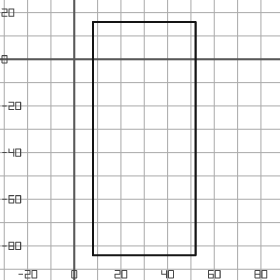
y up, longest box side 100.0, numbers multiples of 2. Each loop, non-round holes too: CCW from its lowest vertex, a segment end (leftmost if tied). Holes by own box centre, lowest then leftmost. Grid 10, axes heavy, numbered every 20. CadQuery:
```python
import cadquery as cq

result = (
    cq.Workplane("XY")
    .moveTo(8.0, -84.0)
    .lineTo(52.0, -84.0)
    .lineTo(52.0, 16.0)
    .lineTo(8.0, 16.0)
    .close()
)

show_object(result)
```